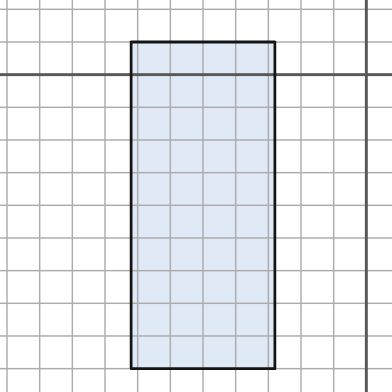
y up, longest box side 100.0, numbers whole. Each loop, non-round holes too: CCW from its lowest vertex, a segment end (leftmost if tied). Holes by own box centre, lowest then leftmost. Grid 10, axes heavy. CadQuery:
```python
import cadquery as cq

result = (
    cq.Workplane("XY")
    .moveTo(-72.0, -90.0)
    .lineTo(-28.0, -90.0)
    .lineTo(-28.0, 10.0)
    .lineTo(-72.0, 10.0)
    .close()
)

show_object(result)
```